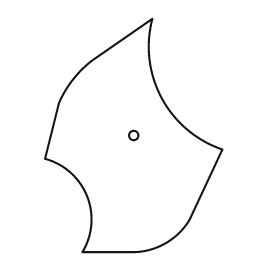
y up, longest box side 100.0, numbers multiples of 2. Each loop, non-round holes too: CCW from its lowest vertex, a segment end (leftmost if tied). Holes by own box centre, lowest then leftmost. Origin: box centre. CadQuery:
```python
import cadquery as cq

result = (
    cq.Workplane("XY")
    .moveTo(-22.0, -50.0)
    .lineTo(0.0, -50.0)
    .threePointArc((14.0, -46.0), (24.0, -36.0))
    .lineTo(38.0, -6.0)
    .threePointArc((12.0, 16.0), (8.0, 50.0))
    .lineTo(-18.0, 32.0)
    .threePointArc((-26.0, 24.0), (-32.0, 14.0))
    .lineTo(-38.0, -10.0)
    .threePointArc((-20.0, -26.0), (-22.0, -50.0))
    .close()
    .moveTo(0.0, 0.0)
    .circle(2.0)
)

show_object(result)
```